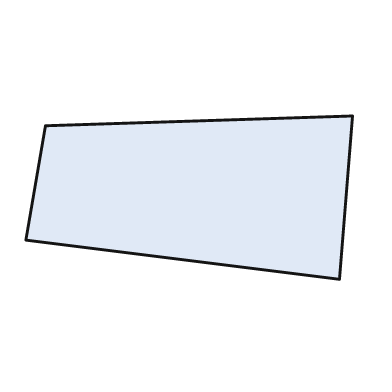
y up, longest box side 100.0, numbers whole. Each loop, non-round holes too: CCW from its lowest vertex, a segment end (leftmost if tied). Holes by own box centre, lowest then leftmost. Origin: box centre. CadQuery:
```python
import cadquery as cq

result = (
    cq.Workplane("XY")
    .moveTo(46.0, -25.0)
    .lineTo(50.0, 25.0)
    .lineTo(-44.0, 22.0)
    .lineTo(-50.0, -13.0)
    .close()
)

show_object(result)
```